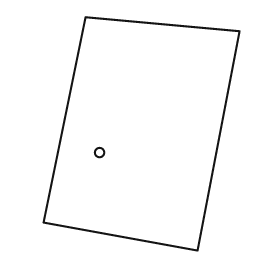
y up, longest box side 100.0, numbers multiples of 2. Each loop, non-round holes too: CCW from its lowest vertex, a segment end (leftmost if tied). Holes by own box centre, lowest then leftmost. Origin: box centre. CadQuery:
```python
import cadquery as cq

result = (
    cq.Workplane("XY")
    .moveTo(24.0, -50.0)
    .lineTo(42.0, 44.0)
    .lineTo(-24.0, 50.0)
    .lineTo(-42.0, -38.0)
    .close()
    .moveTo(-18.0, -8.0)
    .circle(2.0)
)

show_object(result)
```